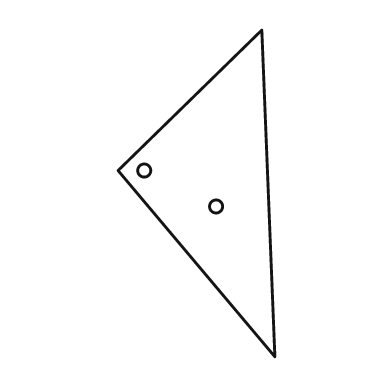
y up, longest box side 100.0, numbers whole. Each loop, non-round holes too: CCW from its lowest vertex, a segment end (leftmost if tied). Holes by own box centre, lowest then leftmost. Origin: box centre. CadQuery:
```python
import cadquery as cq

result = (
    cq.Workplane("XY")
    .moveTo(24.0, -50.0)
    .lineTo(20.0, 50.0)
    .lineTo(-24.0, 7.0)
    .close()
    .moveTo(6.0, -4.0)
    .circle(2.0)
    .moveTo(-16.0, 7.0)
    .circle(2.0)
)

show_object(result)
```